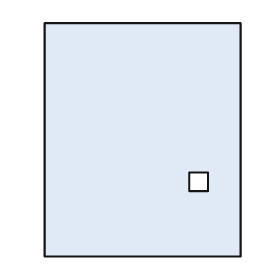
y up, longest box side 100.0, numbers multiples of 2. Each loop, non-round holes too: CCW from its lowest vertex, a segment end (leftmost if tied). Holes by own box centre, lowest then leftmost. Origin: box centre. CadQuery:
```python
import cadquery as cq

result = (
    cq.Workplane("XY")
    .moveTo(-42.0, -50.0)
    .lineTo(42.0, -50.0)
    .lineTo(42.0, 50.0)
    .lineTo(-42.0, 50.0)
    .close()
    .moveTo(20.0, -22.0)
    .lineTo(28.0, -22.0)
    .lineTo(28.0, -14.0)
    .lineTo(20.0, -14.0)
    .close()
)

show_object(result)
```